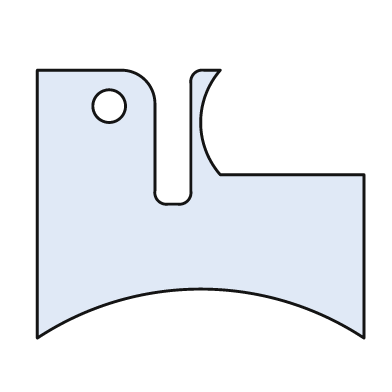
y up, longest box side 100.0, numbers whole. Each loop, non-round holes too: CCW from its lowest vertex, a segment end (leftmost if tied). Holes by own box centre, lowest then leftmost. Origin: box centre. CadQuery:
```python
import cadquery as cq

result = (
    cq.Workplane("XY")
    .moveTo(-50.0, -41.0)
    .threePointArc((0.0, -26.0), (50.0, -41.0))
    .lineTo(50.0, 9.0)
    .lineTo(6.0, 9.0)
    .threePointArc((0.0, 25.0), (6.0, 41.0))
    .lineTo(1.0, 41.0)
    .threePointArc((-2.0, 40.0), (-3.0, 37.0))
    .lineTo(-3.0, 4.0)
    .threePointArc((-4.0, 1.0), (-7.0, 0.0))
    .lineTo(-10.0, 0.0)
    .threePointArc((-13.0, 1.0), (-14.0, 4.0))
    .lineTo(-14.0, 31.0)
    .threePointArc((-17.0, 38.0), (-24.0, 41.0))
    .lineTo(-50.0, 41.0)
    .close()
    .moveTo(-28.0, 30.0)
    .circle(5.0)
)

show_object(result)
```